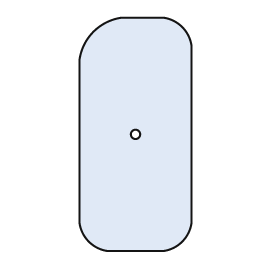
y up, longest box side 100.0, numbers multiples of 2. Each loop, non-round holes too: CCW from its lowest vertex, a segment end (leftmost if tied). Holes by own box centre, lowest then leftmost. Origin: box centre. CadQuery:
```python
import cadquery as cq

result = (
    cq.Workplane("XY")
    .moveTo(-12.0, -50.0)
    .lineTo(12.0, -50.0)
    .threePointArc((20.0, -46.0), (24.0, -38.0))
    .lineTo(24.0, 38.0)
    .threePointArc((20.0, 46.0), (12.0, 50.0))
    .lineTo(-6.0, 50.0)
    .threePointArc((-18.0, 44.0), (-24.0, 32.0))
    .lineTo(-24.0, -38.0)
    .threePointArc((-20.0, -46.0), (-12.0, -50.0))
    .close()
    .moveTo(0.0, 0.0)
    .circle(2.0)
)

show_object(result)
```